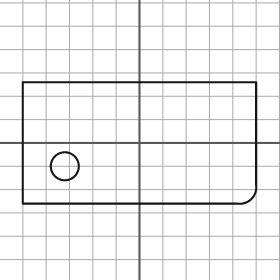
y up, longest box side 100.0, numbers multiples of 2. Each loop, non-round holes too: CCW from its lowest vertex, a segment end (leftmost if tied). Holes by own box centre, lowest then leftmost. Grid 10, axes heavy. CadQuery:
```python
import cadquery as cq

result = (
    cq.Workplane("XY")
    .moveTo(-50.0, -26.0)
    .lineTo(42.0, -26.0)
    .threePointArc((48.0, -24.0), (50.0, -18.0))
    .lineTo(50.0, 26.0)
    .lineTo(-50.0, 26.0)
    .close()
    .moveTo(-32.0, -10.0)
    .circle(6.0)
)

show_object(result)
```